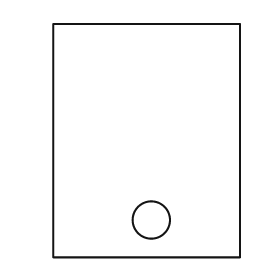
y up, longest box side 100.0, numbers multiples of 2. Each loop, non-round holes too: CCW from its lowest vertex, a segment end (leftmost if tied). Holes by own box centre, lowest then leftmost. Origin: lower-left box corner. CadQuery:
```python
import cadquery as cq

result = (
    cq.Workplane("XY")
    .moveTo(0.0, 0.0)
    .lineTo(80.0, 0.0)
    .lineTo(80.0, 100.0)
    .lineTo(0.0, 100.0)
    .close()
    .moveTo(42.0, 16.0)
    .circle(8.0)
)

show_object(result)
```